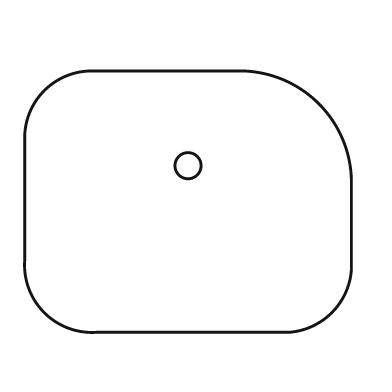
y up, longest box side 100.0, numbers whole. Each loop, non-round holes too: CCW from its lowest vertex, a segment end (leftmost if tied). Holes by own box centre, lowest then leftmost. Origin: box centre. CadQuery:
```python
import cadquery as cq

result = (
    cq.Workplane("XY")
    .moveTo(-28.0, -40.0)
    .lineTo(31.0, -40.0)
    .threePointArc((44.0, -34.0), (50.0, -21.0))
    .lineTo(50.0, 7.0)
    .threePointArc((40.0, 30.0), (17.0, 40.0))
    .lineTo(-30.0, 40.0)
    .threePointArc((-44.0, 34.0), (-50.0, 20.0))
    .lineTo(-50.0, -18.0)
    .threePointArc((-44.0, -34.0), (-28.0, -40.0))
    .close()
    .moveTo(0.0, 11.0)
    .circle(4.0)
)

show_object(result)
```